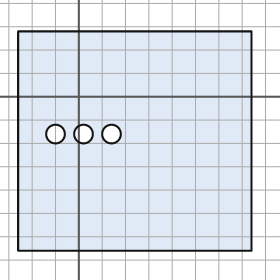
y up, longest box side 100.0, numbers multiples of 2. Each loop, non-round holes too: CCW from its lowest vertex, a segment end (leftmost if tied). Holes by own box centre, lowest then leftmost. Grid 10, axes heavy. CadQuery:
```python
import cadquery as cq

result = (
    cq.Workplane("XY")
    .moveTo(-26.0, -66.0)
    .lineTo(74.0, -66.0)
    .lineTo(74.0, 28.0)
    .lineTo(-26.0, 28.0)
    .close()
    .moveTo(-10.0, -16.0)
    .circle(4.0)
    .moveTo(2.0, -16.0)
    .circle(4.0)
    .moveTo(14.0, -16.0)
    .circle(4.0)
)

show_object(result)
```